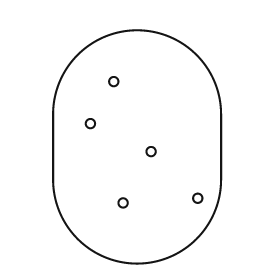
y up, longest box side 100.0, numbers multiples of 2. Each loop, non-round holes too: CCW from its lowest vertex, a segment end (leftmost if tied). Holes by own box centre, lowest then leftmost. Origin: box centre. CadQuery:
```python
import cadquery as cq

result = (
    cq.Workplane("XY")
    .moveTo(-36.0, -14.0)
    .threePointArc((0.0, -50.0), (36.0, -14.0))
    .lineTo(36.0, 14.0)
    .threePointArc((0.0, 50.0), (-36.0, 14.0))
    .close()
    .moveTo(-6.0, -24.0)
    .circle(2.0)
    .moveTo(26.0, -22.0)
    .circle(2.0)
    .moveTo(6.0, -2.0)
    .circle(2.0)
    .moveTo(-20.0, 10.0)
    .circle(2.0)
    .moveTo(-10.0, 28.0)
    .circle(2.0)
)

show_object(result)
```